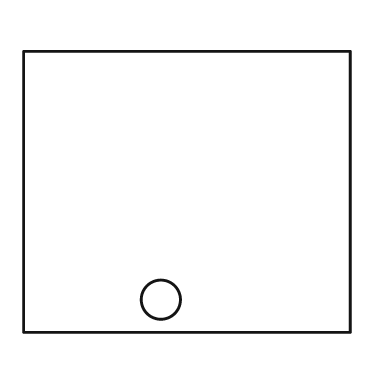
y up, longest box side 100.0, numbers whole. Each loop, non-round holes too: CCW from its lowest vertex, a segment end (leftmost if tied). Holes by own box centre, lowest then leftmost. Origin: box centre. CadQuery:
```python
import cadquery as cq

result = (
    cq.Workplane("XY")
    .moveTo(-50.0, -43.0)
    .lineTo(50.0, -43.0)
    .lineTo(50.0, 43.0)
    .lineTo(-50.0, 43.0)
    .close()
    .moveTo(-8.0, -33.0)
    .circle(6.0)
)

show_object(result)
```